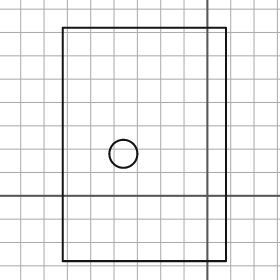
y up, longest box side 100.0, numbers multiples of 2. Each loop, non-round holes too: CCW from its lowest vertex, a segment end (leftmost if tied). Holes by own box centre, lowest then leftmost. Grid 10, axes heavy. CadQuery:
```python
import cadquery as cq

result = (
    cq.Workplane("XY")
    .moveTo(-62.0, -28.0)
    .lineTo(8.0, -28.0)
    .lineTo(8.0, 72.0)
    .lineTo(-62.0, 72.0)
    .close()
    .moveTo(-36.0, 18.0)
    .circle(6.0)
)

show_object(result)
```